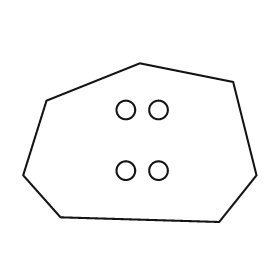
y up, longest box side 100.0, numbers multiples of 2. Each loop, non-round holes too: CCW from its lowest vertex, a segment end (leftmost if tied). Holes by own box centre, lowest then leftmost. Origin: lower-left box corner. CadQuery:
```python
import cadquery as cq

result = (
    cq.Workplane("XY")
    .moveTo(84.0, 0.0)
    .lineTo(100.0, 20.0)
    .lineTo(90.0, 60.0)
    .lineTo(50.0, 68.0)
    .lineTo(10.0, 52.0)
    .lineTo(0.0, 20.0)
    .lineTo(16.0, 2.0)
    .close()
    .moveTo(44.0, 22.0)
    .circle(4.0)
    .moveTo(58.0, 22.0)
    .circle(4.0)
    .moveTo(44.0, 48.0)
    .circle(4.0)
    .moveTo(58.0, 48.0)
    .circle(4.0)
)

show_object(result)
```